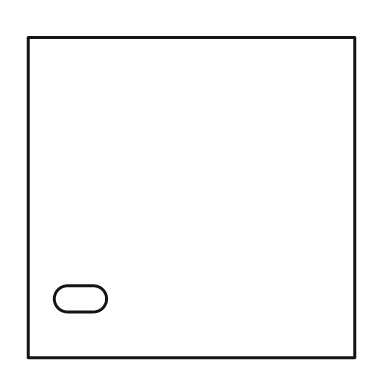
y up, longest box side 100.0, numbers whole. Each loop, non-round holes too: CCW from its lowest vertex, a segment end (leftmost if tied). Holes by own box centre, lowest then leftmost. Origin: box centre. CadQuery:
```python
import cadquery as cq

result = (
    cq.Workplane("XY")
    .moveTo(-50.0, -49.0)
    .lineTo(50.0, -49.0)
    .lineTo(50.0, 49.0)
    .lineTo(-50.0, 49.0)
    .close()
    .moveTo(-38.0, -35.0)
    .lineTo(-30.0, -35.0)
    .threePointArc((-26.0, -31.0), (-30.0, -27.0))
    .lineTo(-38.0, -27.0)
    .threePointArc((-42.0, -31.0), (-38.0, -35.0))
    .close()
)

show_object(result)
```